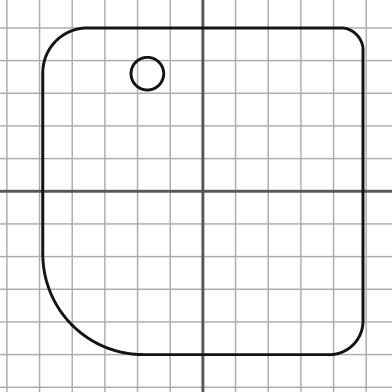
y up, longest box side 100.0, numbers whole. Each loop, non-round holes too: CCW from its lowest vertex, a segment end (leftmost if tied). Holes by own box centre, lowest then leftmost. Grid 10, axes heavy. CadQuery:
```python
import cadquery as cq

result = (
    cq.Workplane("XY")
    .moveTo(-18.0, -50.0)
    .lineTo(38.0, -50.0)
    .threePointArc((46.0, -47.0), (49.0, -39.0))
    .lineTo(49.0, 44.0)
    .threePointArc((47.0, 48.0), (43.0, 50.0))
    .lineTo(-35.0, 50.0)
    .threePointArc((-45.0, 46.0), (-49.0, 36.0))
    .lineTo(-49.0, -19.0)
    .threePointArc((-40.0, -41.0), (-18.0, -50.0))
    .close()
    .moveTo(-17.0, 36.0)
    .circle(5.0)
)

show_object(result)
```